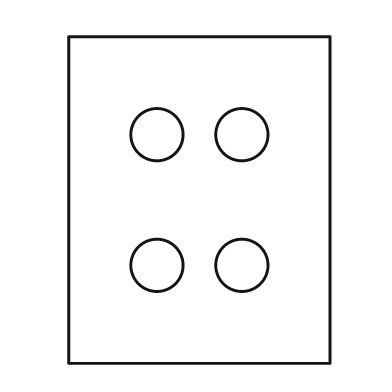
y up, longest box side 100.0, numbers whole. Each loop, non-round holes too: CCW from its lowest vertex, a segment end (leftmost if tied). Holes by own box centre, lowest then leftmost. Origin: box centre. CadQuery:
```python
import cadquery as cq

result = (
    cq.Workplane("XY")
    .moveTo(-40.0, -50.0)
    .lineTo(40.0, -50.0)
    .lineTo(40.0, 50.0)
    .lineTo(-40.0, 50.0)
    .close()
    .moveTo(-13.0, -20.0)
    .circle(8.0)
    .moveTo(13.0, -20.0)
    .circle(8.0)
    .moveTo(-13.0, 20.0)
    .circle(8.0)
    .moveTo(13.0, 20.0)
    .circle(8.0)
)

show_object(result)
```